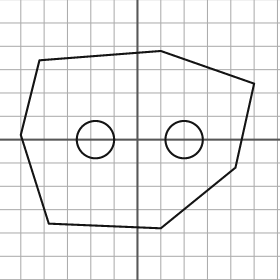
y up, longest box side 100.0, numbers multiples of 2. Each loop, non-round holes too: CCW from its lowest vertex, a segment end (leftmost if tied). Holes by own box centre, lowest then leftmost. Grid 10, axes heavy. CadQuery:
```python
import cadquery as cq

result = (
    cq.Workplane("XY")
    .moveTo(10.0, -38.0)
    .lineTo(42.0, -12.0)
    .lineTo(50.0, 24.0)
    .lineTo(10.0, 38.0)
    .lineTo(-42.0, 34.0)
    .lineTo(-50.0, 2.0)
    .lineTo(-38.0, -36.0)
    .close()
    .moveTo(-18.0, 0.0)
    .circle(8.0)
    .moveTo(20.0, 0.0)
    .circle(8.0)
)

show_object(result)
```